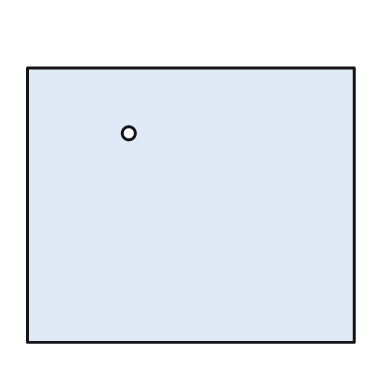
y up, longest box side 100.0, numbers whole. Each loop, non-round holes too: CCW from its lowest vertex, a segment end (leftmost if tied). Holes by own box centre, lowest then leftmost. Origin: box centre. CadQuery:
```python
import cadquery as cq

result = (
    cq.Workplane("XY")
    .moveTo(-50.0, -42.0)
    .lineTo(50.0, -42.0)
    .lineTo(50.0, 42.0)
    .lineTo(-50.0, 42.0)
    .close()
    .moveTo(-19.0, 22.0)
    .circle(2.0)
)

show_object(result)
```